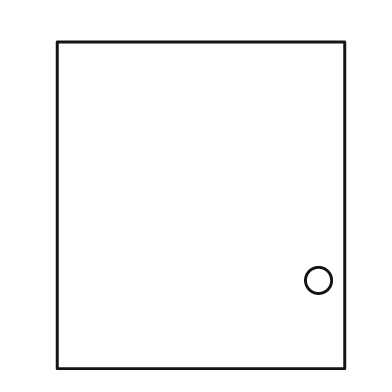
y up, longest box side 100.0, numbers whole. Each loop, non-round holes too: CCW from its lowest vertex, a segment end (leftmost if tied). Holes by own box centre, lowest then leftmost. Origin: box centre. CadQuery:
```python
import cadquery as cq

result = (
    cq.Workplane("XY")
    .moveTo(-44.0, -50.0)
    .lineTo(44.0, -50.0)
    .lineTo(44.0, 50.0)
    .lineTo(-44.0, 50.0)
    .close()
    .moveTo(36.0, -23.0)
    .circle(4.0)
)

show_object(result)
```